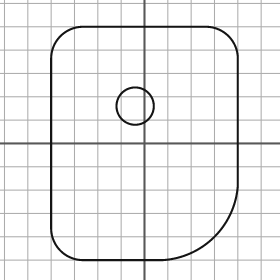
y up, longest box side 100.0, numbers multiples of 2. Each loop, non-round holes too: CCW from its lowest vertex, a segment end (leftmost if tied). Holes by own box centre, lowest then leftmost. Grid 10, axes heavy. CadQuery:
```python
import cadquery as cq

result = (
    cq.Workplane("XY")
    .moveTo(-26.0, -50.0)
    .lineTo(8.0, -50.0)
    .threePointArc((30.0, -40.0), (40.0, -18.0))
    .lineTo(40.0, 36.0)
    .threePointArc((36.0, 46.0), (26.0, 50.0))
    .lineTo(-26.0, 50.0)
    .threePointArc((-36.0, 46.0), (-40.0, 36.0))
    .lineTo(-40.0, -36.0)
    .threePointArc((-36.0, -46.0), (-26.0, -50.0))
    .close()
    .moveTo(-4.0, 16.0)
    .circle(8.0)
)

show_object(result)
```